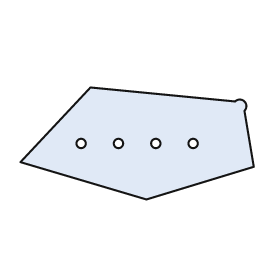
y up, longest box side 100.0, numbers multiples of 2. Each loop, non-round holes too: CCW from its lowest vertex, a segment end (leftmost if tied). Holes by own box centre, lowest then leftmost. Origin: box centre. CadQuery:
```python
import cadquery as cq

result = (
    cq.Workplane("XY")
    .moveTo(4.0, -24.0)
    .lineTo(50.0, -10.0)
    .lineTo(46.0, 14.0)
    .threePointArc((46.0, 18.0), (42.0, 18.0))
    .lineTo(-20.0, 24.0)
    .lineTo(-50.0, -8.0)
    .close()
    .moveTo(-24.0, 0.0)
    .circle(2.0)
    .moveTo(-8.0, 0.0)
    .circle(2.0)
    .moveTo(8.0, 0.0)
    .circle(2.0)
    .moveTo(24.0, 0.0)
    .circle(2.0)
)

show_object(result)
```